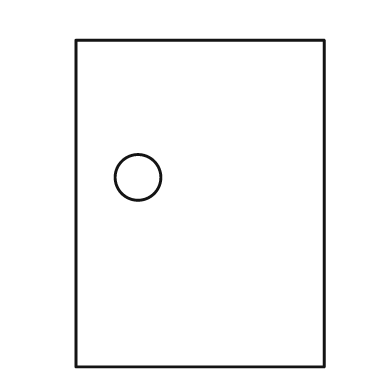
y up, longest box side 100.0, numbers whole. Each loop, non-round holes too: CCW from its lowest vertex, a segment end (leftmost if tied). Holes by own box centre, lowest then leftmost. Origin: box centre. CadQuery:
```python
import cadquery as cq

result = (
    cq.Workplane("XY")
    .moveTo(-38.0, -50.0)
    .lineTo(38.0, -50.0)
    .lineTo(38.0, 50.0)
    .lineTo(-38.0, 50.0)
    .close()
    .moveTo(-19.0, 8.0)
    .circle(7.0)
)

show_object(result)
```